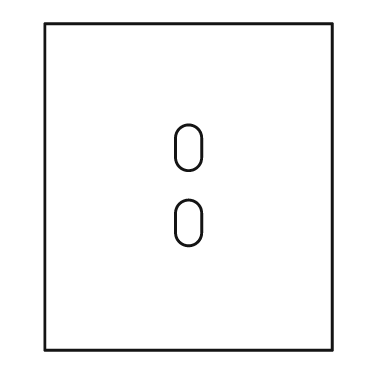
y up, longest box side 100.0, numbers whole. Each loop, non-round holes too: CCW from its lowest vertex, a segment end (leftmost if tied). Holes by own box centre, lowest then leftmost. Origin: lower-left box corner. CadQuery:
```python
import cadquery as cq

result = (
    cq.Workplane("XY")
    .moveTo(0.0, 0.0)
    .lineTo(88.0, 0.0)
    .lineTo(88.0, 100.0)
    .lineTo(0.0, 100.0)
    .close()
    .moveTo(40.0, 36.0)
    .threePointArc((44.0, 32.0), (48.0, 36.0))
    .lineTo(48.0, 42.0)
    .threePointArc((44.0, 46.0), (40.0, 42.0))
    .close()
    .moveTo(40.0, 59.0)
    .threePointArc((44.0, 55.0), (48.0, 59.0))
    .lineTo(48.0, 65.0)
    .threePointArc((44.0, 69.0), (40.0, 65.0))
    .close()
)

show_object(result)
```